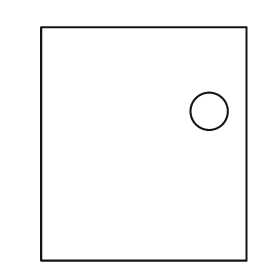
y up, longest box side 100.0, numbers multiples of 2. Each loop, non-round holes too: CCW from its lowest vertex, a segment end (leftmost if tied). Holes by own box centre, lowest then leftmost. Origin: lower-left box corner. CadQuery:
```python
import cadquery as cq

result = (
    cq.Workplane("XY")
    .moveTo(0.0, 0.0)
    .lineTo(88.0, 0.0)
    .lineTo(88.0, 100.0)
    .lineTo(0.0, 100.0)
    .close()
    .moveTo(72.0, 64.0)
    .circle(8.0)
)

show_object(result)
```